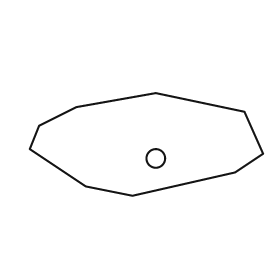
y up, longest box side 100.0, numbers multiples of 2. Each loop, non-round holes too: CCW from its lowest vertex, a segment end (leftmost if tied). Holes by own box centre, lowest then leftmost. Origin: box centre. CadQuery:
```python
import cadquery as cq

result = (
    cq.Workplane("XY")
    .moveTo(-6.0, -22.0)
    .lineTo(38.0, -12.0)
    .lineTo(50.0, -4.0)
    .lineTo(42.0, 14.0)
    .lineTo(4.0, 22.0)
    .lineTo(-30.0, 16.0)
    .lineTo(-46.0, 8.0)
    .lineTo(-50.0, -2.0)
    .lineTo(-26.0, -18.0)
    .close()
    .moveTo(4.0, -6.0)
    .circle(4.0)
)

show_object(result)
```